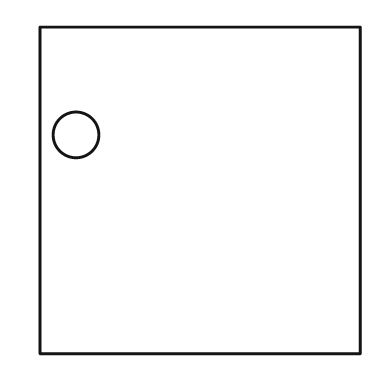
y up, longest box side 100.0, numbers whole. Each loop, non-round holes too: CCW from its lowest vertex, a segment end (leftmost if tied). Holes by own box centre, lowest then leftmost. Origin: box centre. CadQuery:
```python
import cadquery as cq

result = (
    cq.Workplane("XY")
    .moveTo(-49.0, -50.0)
    .lineTo(49.0, -50.0)
    .lineTo(49.0, 50.0)
    .lineTo(-49.0, 50.0)
    .close()
    .moveTo(-38.0, 17.0)
    .circle(7.0)
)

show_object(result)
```